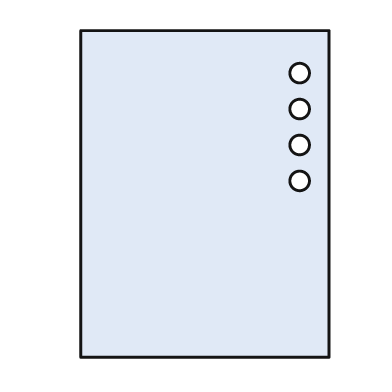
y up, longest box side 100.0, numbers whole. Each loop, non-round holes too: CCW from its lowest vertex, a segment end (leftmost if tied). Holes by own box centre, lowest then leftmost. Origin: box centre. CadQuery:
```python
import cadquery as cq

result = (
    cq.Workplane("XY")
    .moveTo(-38.0, -50.0)
    .lineTo(38.0, -50.0)
    .lineTo(38.0, 50.0)
    .lineTo(-38.0, 50.0)
    .close()
    .moveTo(29.0, 4.0)
    .circle(3.0)
    .moveTo(29.0, 15.0)
    .circle(3.0)
    .moveTo(29.0, 26.0)
    .circle(3.0)
    .moveTo(29.0, 37.0)
    .circle(3.0)
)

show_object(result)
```